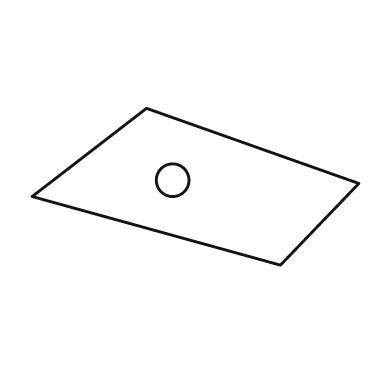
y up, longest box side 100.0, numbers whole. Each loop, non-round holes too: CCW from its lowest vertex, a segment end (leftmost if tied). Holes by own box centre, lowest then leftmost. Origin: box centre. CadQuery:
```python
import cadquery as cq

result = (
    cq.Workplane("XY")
    .moveTo(26.0, -24.0)
    .lineTo(50.0, 1.0)
    .lineTo(-15.0, 24.0)
    .lineTo(-50.0, -3.0)
    .close()
    .moveTo(-7.0, 2.0)
    .circle(5.0)
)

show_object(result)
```